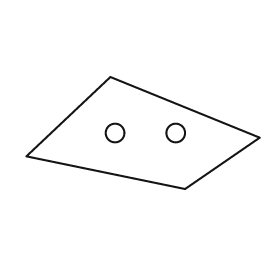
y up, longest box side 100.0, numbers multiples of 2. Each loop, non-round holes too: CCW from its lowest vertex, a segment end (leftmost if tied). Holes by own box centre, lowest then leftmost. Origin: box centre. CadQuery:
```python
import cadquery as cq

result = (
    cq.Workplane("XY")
    .moveTo(18.0, -24.0)
    .lineTo(50.0, -2.0)
    .lineTo(-14.0, 24.0)
    .lineTo(-50.0, -10.0)
    .close()
    .moveTo(-12.0, 0.0)
    .circle(4.0)
    .moveTo(14.0, 0.0)
    .circle(4.0)
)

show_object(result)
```